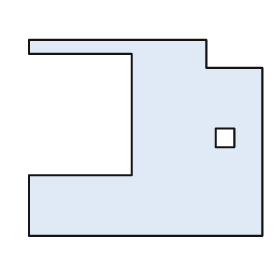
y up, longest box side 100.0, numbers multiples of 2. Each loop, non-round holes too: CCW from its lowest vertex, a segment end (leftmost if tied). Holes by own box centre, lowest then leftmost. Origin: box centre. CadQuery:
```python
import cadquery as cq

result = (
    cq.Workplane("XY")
    .moveTo(-50.0, -42.0)
    .lineTo(50.0, -42.0)
    .lineTo(50.0, 30.0)
    .lineTo(26.0, 30.0)
    .lineTo(26.0, 42.0)
    .lineTo(-50.0, 42.0)
    .lineTo(-50.0, 36.0)
    .lineTo(-6.0, 36.0)
    .lineTo(-6.0, -16.0)
    .lineTo(-50.0, -16.0)
    .close()
    .moveTo(30.0, -4.0)
    .lineTo(38.0, -4.0)
    .lineTo(38.0, 4.0)
    .lineTo(30.0, 4.0)
    .close()
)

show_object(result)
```